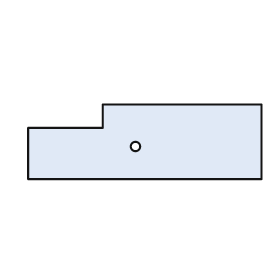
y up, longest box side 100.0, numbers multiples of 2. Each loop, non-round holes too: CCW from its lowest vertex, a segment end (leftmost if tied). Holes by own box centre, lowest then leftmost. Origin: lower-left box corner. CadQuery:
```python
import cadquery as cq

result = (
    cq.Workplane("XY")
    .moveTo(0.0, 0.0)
    .lineTo(100.0, 0.0)
    .lineTo(100.0, 32.0)
    .lineTo(32.0, 32.0)
    .lineTo(32.0, 22.0)
    .lineTo(0.0, 22.0)
    .close()
    .moveTo(46.0, 14.0)
    .circle(2.0)
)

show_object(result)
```